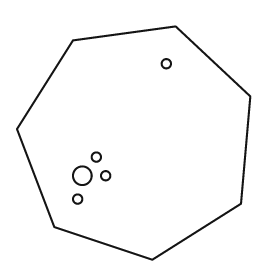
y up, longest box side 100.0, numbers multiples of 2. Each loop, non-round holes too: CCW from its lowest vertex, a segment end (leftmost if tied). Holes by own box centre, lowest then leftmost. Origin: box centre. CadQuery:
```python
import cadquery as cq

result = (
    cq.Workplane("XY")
    .moveTo(8.0, -50.0)
    .lineTo(46.0, -26.0)
    .lineTo(50.0, 20.0)
    .lineTo(18.0, 50.0)
    .lineTo(-26.0, 44.0)
    .lineTo(-50.0, 6.0)
    .lineTo(-34.0, -36.0)
    .close()
    .moveTo(-24.0, -24.0)
    .circle(2.0)
    .moveTo(-22.0, -14.0)
    .circle(4.0)
    .moveTo(-12.0, -14.0)
    .circle(2.0)
    .moveTo(-16.0, -6.0)
    .circle(2.0)
    .moveTo(14.0, 34.0)
    .circle(2.0)
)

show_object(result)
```